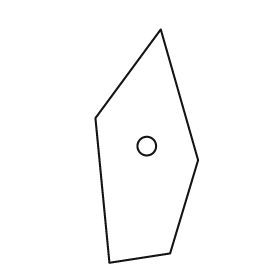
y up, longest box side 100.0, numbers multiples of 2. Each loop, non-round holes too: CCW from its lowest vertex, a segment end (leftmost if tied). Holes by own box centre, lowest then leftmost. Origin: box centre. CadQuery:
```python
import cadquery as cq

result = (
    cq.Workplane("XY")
    .moveTo(-16.0, -50.0)
    .lineTo(10.0, -46.0)
    .lineTo(22.0, -6.0)
    .lineTo(6.0, 50.0)
    .lineTo(-22.0, 12.0)
    .close()
    .moveTo(0.0, 0.0)
    .circle(4.0)
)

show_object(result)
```